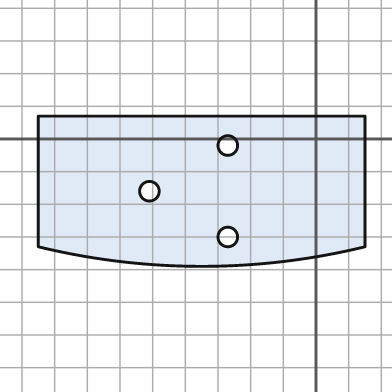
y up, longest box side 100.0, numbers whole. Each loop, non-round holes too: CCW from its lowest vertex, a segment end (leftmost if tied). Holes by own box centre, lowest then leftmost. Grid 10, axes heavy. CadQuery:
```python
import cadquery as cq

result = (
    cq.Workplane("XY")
    .moveTo(-85.0, -33.0)
    .threePointArc((-35.0, -39.0), (15.0, -33.0))
    .lineTo(15.0, 7.0)
    .lineTo(-85.0, 7.0)
    .close()
    .moveTo(-27.0, -30.0)
    .circle(3.0)
    .moveTo(-51.0, -16.0)
    .circle(3.0)
    .moveTo(-27.0, -2.0)
    .circle(3.0)
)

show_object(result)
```